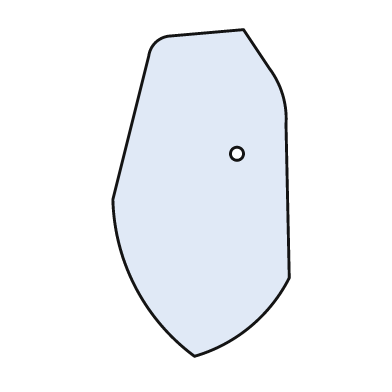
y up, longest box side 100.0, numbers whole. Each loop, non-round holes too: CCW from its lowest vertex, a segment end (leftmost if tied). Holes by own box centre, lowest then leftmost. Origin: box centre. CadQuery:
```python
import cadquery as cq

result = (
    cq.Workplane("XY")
    .moveTo(-2.0, -50.0)
    .threePointArc((15.0, -41.0), (27.0, -26.0))
    .lineTo(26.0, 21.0)
    .threePointArc((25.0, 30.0), (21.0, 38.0))
    .lineTo(13.0, 50.0)
    .lineTo(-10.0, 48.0)
    .threePointArc((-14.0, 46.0), (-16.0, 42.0))
    .lineTo(-27.0, -2.0)
    .threePointArc((-20.0, -29.0), (-2.0, -50.0))
    .close()
    .moveTo(11.0, 12.0)
    .circle(2.0)
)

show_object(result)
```